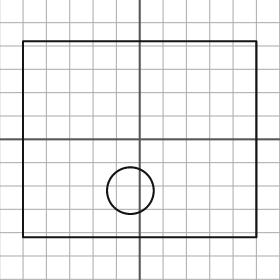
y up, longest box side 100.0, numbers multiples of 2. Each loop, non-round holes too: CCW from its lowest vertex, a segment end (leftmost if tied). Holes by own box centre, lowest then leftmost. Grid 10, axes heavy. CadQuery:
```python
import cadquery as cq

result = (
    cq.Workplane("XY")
    .moveTo(-50.0, -42.0)
    .lineTo(50.0, -42.0)
    .lineTo(50.0, 42.0)
    .lineTo(-50.0, 42.0)
    .close()
    .moveTo(-4.0, -22.0)
    .circle(10.0)
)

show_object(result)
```